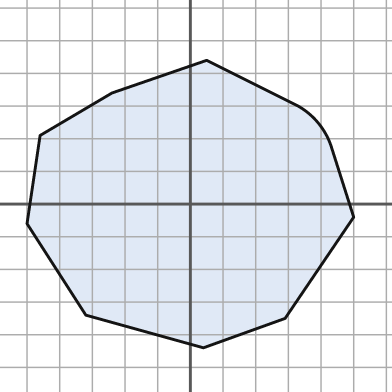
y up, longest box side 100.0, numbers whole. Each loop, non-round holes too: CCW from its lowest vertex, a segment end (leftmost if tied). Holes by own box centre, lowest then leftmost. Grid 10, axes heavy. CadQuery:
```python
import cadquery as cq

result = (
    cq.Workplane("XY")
    .moveTo(4.0, -44.0)
    .lineTo(29.0, -35.0)
    .lineTo(50.0, -4.0)
    .lineTo(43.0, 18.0)
    .threePointArc((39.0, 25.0), (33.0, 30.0))
    .lineTo(5.0, 44.0)
    .lineTo(-24.0, 34.0)
    .lineTo(-46.0, 21.0)
    .lineTo(-50.0, -6.0)
    .lineTo(-32.0, -34.0)
    .close()
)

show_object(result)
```